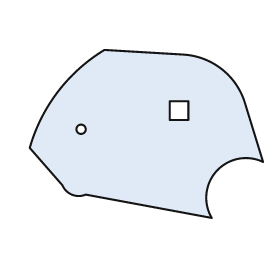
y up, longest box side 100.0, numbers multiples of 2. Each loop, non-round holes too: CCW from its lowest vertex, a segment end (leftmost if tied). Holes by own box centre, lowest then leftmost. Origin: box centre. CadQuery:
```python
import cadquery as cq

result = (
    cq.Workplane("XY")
    .moveTo(28.0, -36.0)
    .threePointArc((30.0, -16.0), (50.0, -12.0))
    .lineTo(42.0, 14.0)
    .threePointArc((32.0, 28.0), (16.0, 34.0))
    .lineTo(-18.0, 36.0)
    .threePointArc((-38.0, 18.0), (-50.0, -6.0))
    .lineTo(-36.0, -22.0)
    .threePointArc((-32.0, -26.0), (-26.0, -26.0))
    .close()
    .moveTo(-28.0, 2.0)
    .circle(2.0)
    .moveTo(10.0, 6.0)
    .lineTo(18.0, 6.0)
    .lineTo(18.0, 14.0)
    .lineTo(10.0, 14.0)
    .close()
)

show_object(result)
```